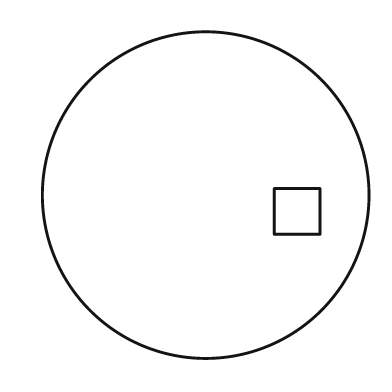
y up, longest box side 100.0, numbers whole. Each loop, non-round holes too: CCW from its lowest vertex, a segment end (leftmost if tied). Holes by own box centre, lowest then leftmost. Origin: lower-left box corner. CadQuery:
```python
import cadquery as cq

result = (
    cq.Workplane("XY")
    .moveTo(50.0, 50.0)
    .circle(50.0)
    .moveTo(71.0, 38.0)
    .lineTo(85.0, 38.0)
    .lineTo(85.0, 52.0)
    .lineTo(71.0, 52.0)
    .close()
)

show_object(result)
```